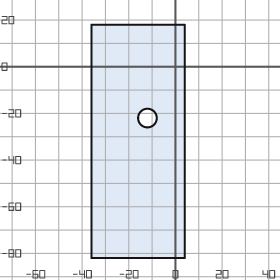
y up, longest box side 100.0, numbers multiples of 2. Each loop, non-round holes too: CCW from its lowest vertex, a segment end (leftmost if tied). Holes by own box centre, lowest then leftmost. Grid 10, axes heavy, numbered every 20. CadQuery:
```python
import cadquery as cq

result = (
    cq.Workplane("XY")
    .moveTo(-36.0, -82.0)
    .lineTo(4.0, -82.0)
    .lineTo(4.0, 18.0)
    .lineTo(-36.0, 18.0)
    .close()
    .moveTo(-12.0, -22.0)
    .circle(4.0)
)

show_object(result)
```